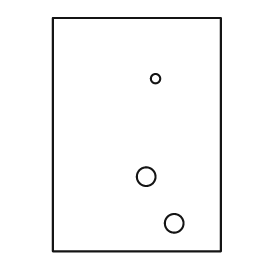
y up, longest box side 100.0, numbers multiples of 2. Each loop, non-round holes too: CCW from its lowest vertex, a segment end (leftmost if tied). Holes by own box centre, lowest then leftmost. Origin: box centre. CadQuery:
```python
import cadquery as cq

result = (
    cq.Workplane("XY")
    .moveTo(-36.0, -50.0)
    .lineTo(36.0, -50.0)
    .lineTo(36.0, 50.0)
    .lineTo(-36.0, 50.0)
    .close()
    .moveTo(16.0, -38.0)
    .circle(4.0)
    .moveTo(4.0, -18.0)
    .circle(4.0)
    .moveTo(8.0, 24.0)
    .circle(2.0)
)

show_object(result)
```